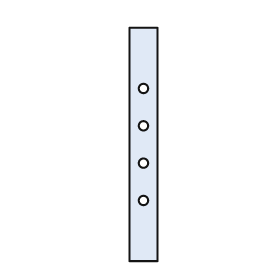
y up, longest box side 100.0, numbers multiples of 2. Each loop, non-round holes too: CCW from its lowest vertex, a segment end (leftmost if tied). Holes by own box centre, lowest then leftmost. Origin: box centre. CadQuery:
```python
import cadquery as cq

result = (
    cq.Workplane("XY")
    .moveTo(-6.0, -50.0)
    .lineTo(6.0, -50.0)
    .lineTo(6.0, 50.0)
    .lineTo(-6.0, 50.0)
    .close()
    .moveTo(0.0, -24.0)
    .circle(2.0)
    .moveTo(0.0, -8.0)
    .circle(2.0)
    .moveTo(0.0, 8.0)
    .circle(2.0)
    .moveTo(0.0, 24.0)
    .circle(2.0)
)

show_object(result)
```